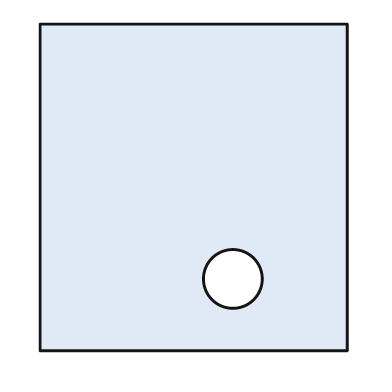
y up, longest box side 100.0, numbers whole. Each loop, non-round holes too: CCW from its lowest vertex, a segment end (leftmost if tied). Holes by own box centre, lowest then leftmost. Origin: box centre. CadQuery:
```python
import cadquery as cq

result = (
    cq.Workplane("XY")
    .moveTo(-47.0, -50.0)
    .lineTo(47.0, -50.0)
    .lineTo(47.0, 50.0)
    .lineTo(-47.0, 50.0)
    .close()
    .moveTo(12.0, -28.0)
    .circle(9.0)
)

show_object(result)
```